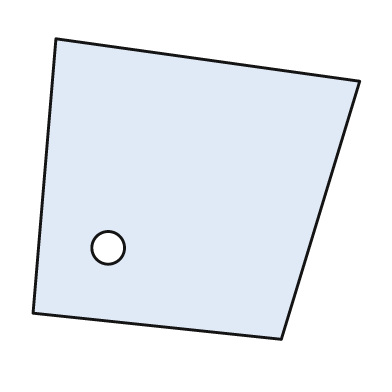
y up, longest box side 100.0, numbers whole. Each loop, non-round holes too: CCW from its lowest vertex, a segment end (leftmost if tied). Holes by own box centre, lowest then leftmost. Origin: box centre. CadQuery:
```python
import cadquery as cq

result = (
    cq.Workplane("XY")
    .moveTo(26.0, -46.0)
    .lineTo(50.0, 33.0)
    .lineTo(-43.0, 46.0)
    .lineTo(-50.0, -38.0)
    .close()
    .moveTo(-27.0, -18.0)
    .circle(5.0)
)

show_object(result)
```